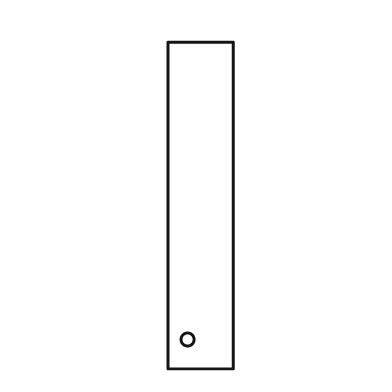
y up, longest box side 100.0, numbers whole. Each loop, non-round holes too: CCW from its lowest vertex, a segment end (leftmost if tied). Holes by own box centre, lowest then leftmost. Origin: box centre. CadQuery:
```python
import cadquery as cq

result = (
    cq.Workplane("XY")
    .moveTo(-10.0, -50.0)
    .lineTo(10.0, -50.0)
    .lineTo(10.0, 50.0)
    .lineTo(-10.0, 50.0)
    .close()
    .moveTo(-4.0, -41.0)
    .circle(2.0)
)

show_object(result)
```